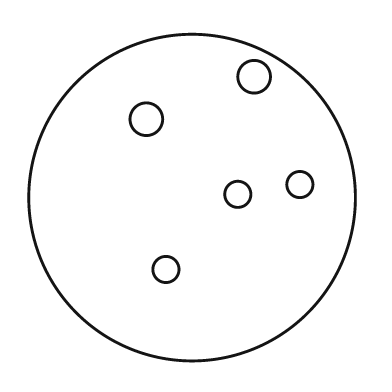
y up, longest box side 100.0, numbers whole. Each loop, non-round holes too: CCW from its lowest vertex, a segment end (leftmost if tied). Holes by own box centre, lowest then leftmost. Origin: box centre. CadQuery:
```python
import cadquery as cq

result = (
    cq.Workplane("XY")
    .moveTo(0.0, 0.0)
    .circle(50.0)
    .moveTo(-8.0, -22.0)
    .circle(4.0)
    .moveTo(14.0, 1.0)
    .circle(4.0)
    .moveTo(33.0, 4.0)
    .circle(4.0)
    .moveTo(-14.0, 24.0)
    .circle(5.0)
    .moveTo(19.0, 37.0)
    .circle(5.0)
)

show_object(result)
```